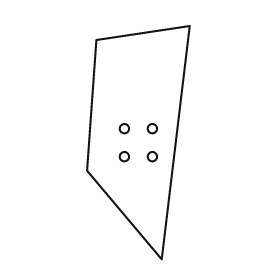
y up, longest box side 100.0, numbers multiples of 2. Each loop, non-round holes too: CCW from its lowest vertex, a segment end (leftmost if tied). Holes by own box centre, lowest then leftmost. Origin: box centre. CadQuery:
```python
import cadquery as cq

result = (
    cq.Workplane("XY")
    .moveTo(10.0, -50.0)
    .lineTo(22.0, 50.0)
    .lineTo(-18.0, 44.0)
    .lineTo(-22.0, -12.0)
    .close()
    .moveTo(-6.0, -6.0)
    .circle(2.0)
    .moveTo(6.0, -6.0)
    .circle(2.0)
    .moveTo(-6.0, 6.0)
    .circle(2.0)
    .moveTo(6.0, 6.0)
    .circle(2.0)
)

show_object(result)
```